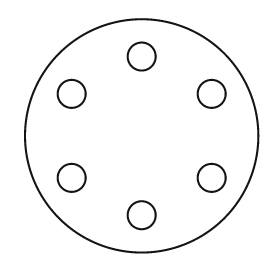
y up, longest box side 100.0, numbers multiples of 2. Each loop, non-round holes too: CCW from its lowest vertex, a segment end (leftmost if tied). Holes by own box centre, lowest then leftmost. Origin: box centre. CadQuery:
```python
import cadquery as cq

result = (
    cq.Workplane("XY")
    .moveTo(0.0, 0.0)
    .circle(50.0)
    .moveTo(0.0, -34.0)
    .circle(6.0)
    .moveTo(-30.0, -18.0)
    .circle(6.0)
    .moveTo(30.0, -18.0)
    .circle(6.0)
    .moveTo(-30.0, 18.0)
    .circle(6.0)
    .moveTo(30.0, 18.0)
    .circle(6.0)
    .moveTo(0.0, 34.0)
    .circle(6.0)
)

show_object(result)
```